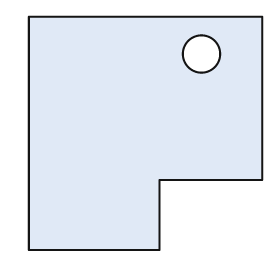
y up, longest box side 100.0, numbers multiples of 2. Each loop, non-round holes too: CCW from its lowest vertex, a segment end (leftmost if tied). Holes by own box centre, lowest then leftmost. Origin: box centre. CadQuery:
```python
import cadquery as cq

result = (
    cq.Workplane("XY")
    .moveTo(-50.0, -50.0)
    .lineTo(6.0, -50.0)
    .lineTo(6.0, -20.0)
    .lineTo(50.0, -20.0)
    .lineTo(50.0, 50.0)
    .lineTo(-50.0, 50.0)
    .close()
    .moveTo(24.0, 34.0)
    .circle(8.0)
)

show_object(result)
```